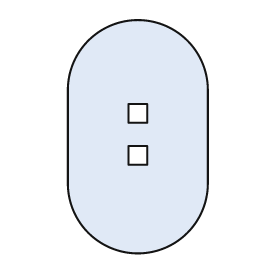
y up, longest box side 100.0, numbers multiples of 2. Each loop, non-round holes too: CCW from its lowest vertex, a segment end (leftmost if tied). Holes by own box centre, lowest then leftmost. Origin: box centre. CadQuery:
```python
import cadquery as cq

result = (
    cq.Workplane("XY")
    .moveTo(-30.0, -20.0)
    .threePointArc((0.0, -50.0), (30.0, -20.0))
    .lineTo(30.0, 20.0)
    .threePointArc((0.0, 50.0), (-30.0, 20.0))
    .close()
    .moveTo(-4.0, -12.0)
    .lineTo(4.0, -12.0)
    .lineTo(4.0, -4.0)
    .lineTo(-4.0, -4.0)
    .close()
    .moveTo(-4.0, 6.0)
    .lineTo(4.0, 6.0)
    .lineTo(4.0, 14.0)
    .lineTo(-4.0, 14.0)
    .close()
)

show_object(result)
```